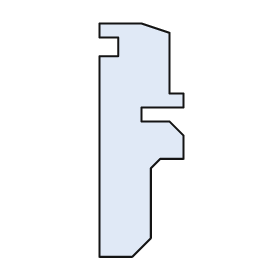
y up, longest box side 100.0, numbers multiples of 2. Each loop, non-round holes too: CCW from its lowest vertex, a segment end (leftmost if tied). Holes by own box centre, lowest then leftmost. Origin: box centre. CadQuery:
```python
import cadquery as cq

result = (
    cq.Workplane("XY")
    .moveTo(-18.0, -50.0)
    .lineTo(-4.0, -50.0)
    .lineTo(4.0, -42.0)
    .lineTo(4.0, -12.0)
    .lineTo(8.0, -8.0)
    .lineTo(18.0, -8.0)
    .lineTo(18.0, 2.0)
    .lineTo(12.0, 8.0)
    .lineTo(0.0, 8.0)
    .lineTo(0.0, 14.0)
    .lineTo(18.0, 14.0)
    .lineTo(18.0, 20.0)
    .lineTo(12.0, 20.0)
    .lineTo(12.0, 46.0)
    .lineTo(0.0, 50.0)
    .lineTo(-18.0, 50.0)
    .lineTo(-18.0, 44.0)
    .lineTo(-10.0, 44.0)
    .lineTo(-10.0, 36.0)
    .lineTo(-18.0, 36.0)
    .close()
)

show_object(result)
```